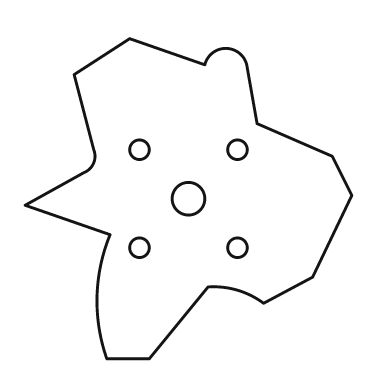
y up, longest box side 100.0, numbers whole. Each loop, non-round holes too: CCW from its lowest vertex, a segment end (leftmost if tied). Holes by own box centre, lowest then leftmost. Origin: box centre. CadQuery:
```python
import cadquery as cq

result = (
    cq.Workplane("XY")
    .moveTo(-25.0, -49.0)
    .lineTo(-12.0, -49.0)
    .lineTo(6.0, -27.0)
    .threePointArc((15.0, -28.0), (23.0, -32.0))
    .lineTo(38.0, -24.0)
    .lineTo(50.0, 1.0)
    .lineTo(44.0, 13.0)
    .lineTo(21.0, 23.0)
    .lineTo(18.0, 40.0)
    .threePointArc((12.0, 46.0), (5.0, 41.0))
    .lineTo(-18.0, 49.0)
    .lineTo(-35.0, 38.0)
    .lineTo(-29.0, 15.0)
    .threePointArc((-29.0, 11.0), (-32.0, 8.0))
    .lineTo(-50.0, -2.0)
    .lineTo(-24.0, -11.0)
    .threePointArc((-28.0, -30.0), (-25.0, -49.0))
    .close()
    .moveTo(-15.0, -15.0)
    .circle(3.0)
    .moveTo(15.0, -15.0)
    .circle(3.0)
    .moveTo(0.0, 0.0)
    .circle(5.0)
    .moveTo(-15.0, 15.0)
    .circle(3.0)
    .moveTo(15.0, 15.0)
    .circle(3.0)
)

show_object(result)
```